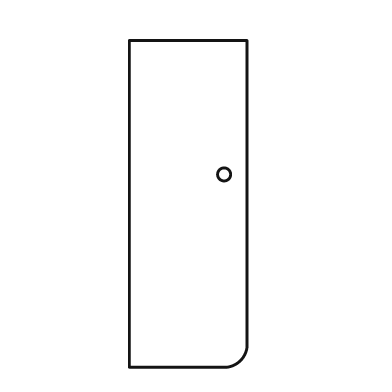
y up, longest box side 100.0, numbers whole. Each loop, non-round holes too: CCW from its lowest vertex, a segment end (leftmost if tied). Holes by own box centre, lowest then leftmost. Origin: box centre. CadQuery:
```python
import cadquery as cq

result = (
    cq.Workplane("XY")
    .moveTo(-18.0, -50.0)
    .lineTo(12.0, -50.0)
    .threePointArc((16.0, -48.0), (18.0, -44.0))
    .lineTo(18.0, 50.0)
    .lineTo(-18.0, 50.0)
    .close()
    .moveTo(11.0, 9.0)
    .circle(2.0)
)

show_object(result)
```